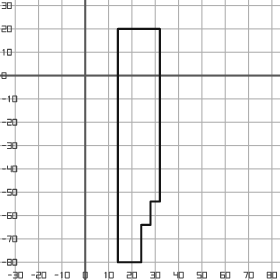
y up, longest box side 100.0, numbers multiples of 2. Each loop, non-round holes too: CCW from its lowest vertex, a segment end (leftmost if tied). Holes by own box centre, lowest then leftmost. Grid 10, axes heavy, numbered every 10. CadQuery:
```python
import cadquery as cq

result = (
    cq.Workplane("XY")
    .moveTo(14.0, -80.0)
    .lineTo(24.0, -80.0)
    .lineTo(24.0, -64.0)
    .lineTo(28.0, -64.0)
    .lineTo(28.0, -54.0)
    .lineTo(32.0, -54.0)
    .lineTo(32.0, 20.0)
    .lineTo(14.0, 20.0)
    .close()
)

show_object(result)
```